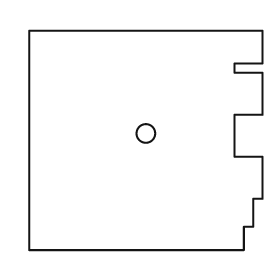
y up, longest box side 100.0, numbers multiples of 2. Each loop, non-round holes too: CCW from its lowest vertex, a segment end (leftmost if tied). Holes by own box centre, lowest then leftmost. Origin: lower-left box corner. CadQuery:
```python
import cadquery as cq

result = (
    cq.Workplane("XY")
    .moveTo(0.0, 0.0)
    .lineTo(92.0, 0.0)
    .lineTo(92.0, 10.0)
    .lineTo(96.0, 10.0)
    .lineTo(96.0, 22.0)
    .lineTo(100.0, 22.0)
    .lineTo(100.0, 40.0)
    .lineTo(88.0, 40.0)
    .lineTo(88.0, 58.0)
    .lineTo(100.0, 58.0)
    .lineTo(100.0, 76.0)
    .lineTo(88.0, 76.0)
    .lineTo(88.0, 80.0)
    .lineTo(100.0, 80.0)
    .lineTo(100.0, 94.0)
    .lineTo(0.0, 94.0)
    .close()
    .moveTo(50.0, 50.0)
    .circle(4.0)
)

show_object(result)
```